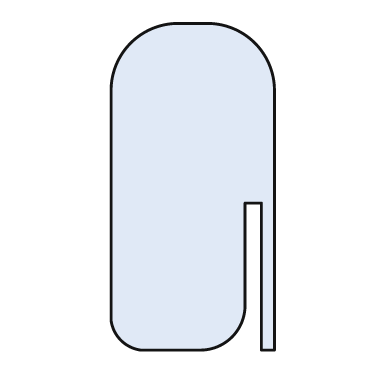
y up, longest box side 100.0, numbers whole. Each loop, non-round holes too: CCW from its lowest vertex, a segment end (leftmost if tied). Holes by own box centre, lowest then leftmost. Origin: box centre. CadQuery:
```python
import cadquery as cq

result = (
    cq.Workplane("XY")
    .moveTo(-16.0, -50.0)
    .lineTo(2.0, -50.0)
    .threePointArc((12.0, -46.0), (16.0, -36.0))
    .lineTo(16.0, -5.0)
    .lineTo(21.0, -5.0)
    .lineTo(21.0, -50.0)
    .lineTo(25.0, -50.0)
    .lineTo(25.0, 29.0)
    .threePointArc((19.0, 44.0), (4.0, 50.0))
    .lineTo(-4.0, 50.0)
    .threePointArc((-19.0, 44.0), (-25.0, 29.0))
    .lineTo(-25.0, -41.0)
    .threePointArc((-22.0, -47.0), (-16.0, -50.0))
    .close()
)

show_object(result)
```